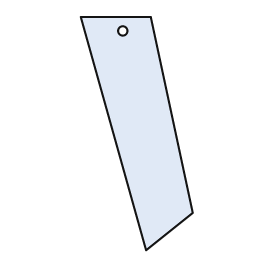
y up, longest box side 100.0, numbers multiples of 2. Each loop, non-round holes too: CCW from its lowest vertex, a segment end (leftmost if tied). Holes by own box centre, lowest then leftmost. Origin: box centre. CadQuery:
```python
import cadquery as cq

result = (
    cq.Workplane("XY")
    .moveTo(4.0, -50.0)
    .lineTo(24.0, -34.0)
    .lineTo(6.0, 50.0)
    .lineTo(-24.0, 50.0)
    .close()
    .moveTo(-6.0, 44.0)
    .circle(2.0)
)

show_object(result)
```